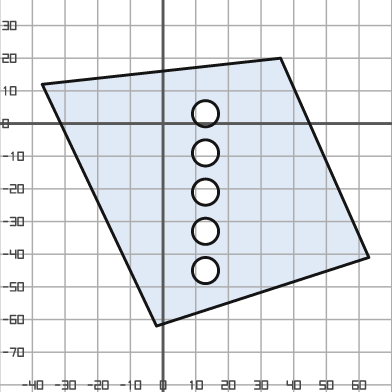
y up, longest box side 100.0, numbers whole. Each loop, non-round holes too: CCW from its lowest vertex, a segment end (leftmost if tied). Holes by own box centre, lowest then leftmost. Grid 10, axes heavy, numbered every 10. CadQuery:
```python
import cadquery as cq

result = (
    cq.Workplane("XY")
    .moveTo(-2.0, -62.0)
    .lineTo(63.0, -41.0)
    .lineTo(36.0, 20.0)
    .lineTo(-37.0, 12.0)
    .close()
    .moveTo(13.0, -45.0)
    .circle(4.0)
    .moveTo(13.0, -33.0)
    .circle(4.0)
    .moveTo(13.0, -21.0)
    .circle(4.0)
    .moveTo(13.0, -9.0)
    .circle(4.0)
    .moveTo(13.0, 3.0)
    .circle(4.0)
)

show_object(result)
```